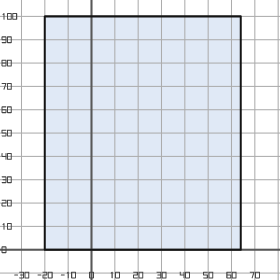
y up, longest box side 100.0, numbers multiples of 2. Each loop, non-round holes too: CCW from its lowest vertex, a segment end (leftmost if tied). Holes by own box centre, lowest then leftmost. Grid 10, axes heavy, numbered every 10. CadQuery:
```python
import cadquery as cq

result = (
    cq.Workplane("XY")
    .moveTo(-20.0, 0.0)
    .lineTo(64.0, 0.0)
    .lineTo(64.0, 100.0)
    .lineTo(-20.0, 100.0)
    .close()
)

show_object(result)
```